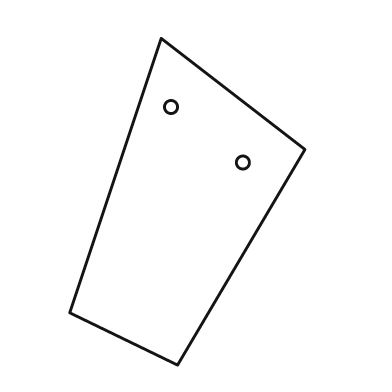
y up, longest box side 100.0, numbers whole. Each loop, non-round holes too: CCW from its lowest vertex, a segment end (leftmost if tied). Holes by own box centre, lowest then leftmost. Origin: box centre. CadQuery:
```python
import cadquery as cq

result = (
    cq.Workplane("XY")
    .moveTo(-3.0, -50.0)
    .lineTo(36.0, 16.0)
    .lineTo(-8.0, 50.0)
    .lineTo(-36.0, -34.0)
    .close()
    .moveTo(17.0, 12.0)
    .circle(2.0)
    .moveTo(-5.0, 29.0)
    .circle(2.0)
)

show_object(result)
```